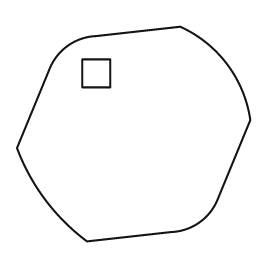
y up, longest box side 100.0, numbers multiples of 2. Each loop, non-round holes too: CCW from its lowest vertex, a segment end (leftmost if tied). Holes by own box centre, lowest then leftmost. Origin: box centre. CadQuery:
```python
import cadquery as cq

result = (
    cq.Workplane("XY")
    .moveTo(-20.0, -46.0)
    .lineTo(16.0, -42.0)
    .threePointArc((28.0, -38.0), (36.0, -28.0))
    .lineTo(50.0, 6.0)
    .threePointArc((40.0, 30.0), (20.0, 46.0))
    .lineTo(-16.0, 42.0)
    .threePointArc((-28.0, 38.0), (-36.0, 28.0))
    .lineTo(-50.0, -6.0)
    .threePointArc((-38.0, -28.0), (-20.0, -46.0))
    .close()
    .moveTo(-22.0, 20.0)
    .lineTo(-10.0, 20.0)
    .lineTo(-10.0, 32.0)
    .lineTo(-22.0, 32.0)
    .close()
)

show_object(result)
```